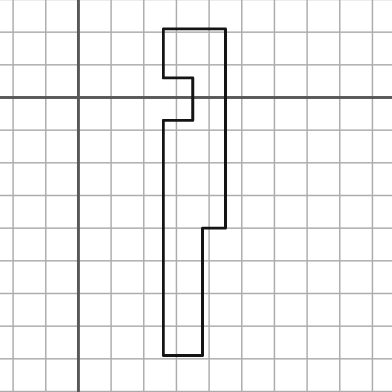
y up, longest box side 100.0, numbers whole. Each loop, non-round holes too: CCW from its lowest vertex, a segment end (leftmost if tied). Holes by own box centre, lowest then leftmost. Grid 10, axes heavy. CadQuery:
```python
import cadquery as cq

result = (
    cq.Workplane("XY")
    .moveTo(26.0, -79.0)
    .lineTo(38.0, -79.0)
    .lineTo(38.0, -40.0)
    .lineTo(45.0, -40.0)
    .lineTo(45.0, 21.0)
    .lineTo(26.0, 21.0)
    .lineTo(26.0, 6.0)
    .lineTo(35.0, 6.0)
    .lineTo(35.0, -7.0)
    .lineTo(26.0, -7.0)
    .close()
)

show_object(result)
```